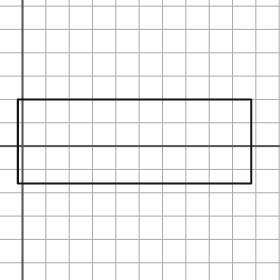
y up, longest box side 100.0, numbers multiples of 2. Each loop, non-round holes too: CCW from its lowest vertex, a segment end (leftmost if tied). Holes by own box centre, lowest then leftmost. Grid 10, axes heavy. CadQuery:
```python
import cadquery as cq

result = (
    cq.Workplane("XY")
    .moveTo(-2.0, -16.0)
    .lineTo(98.0, -16.0)
    .lineTo(98.0, 20.0)
    .lineTo(-2.0, 20.0)
    .close()
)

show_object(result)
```